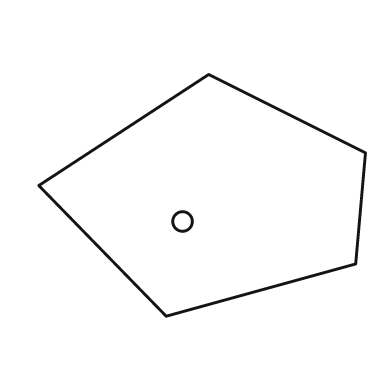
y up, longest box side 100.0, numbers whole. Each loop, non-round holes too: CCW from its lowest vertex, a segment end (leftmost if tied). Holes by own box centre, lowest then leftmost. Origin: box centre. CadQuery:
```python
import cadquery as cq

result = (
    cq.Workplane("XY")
    .moveTo(-11.0, -37.0)
    .lineTo(47.0, -21.0)
    .lineTo(50.0, 13.0)
    .lineTo(2.0, 37.0)
    .lineTo(-50.0, 3.0)
    .close()
    .moveTo(-6.0, -8.0)
    .circle(3.0)
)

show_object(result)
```